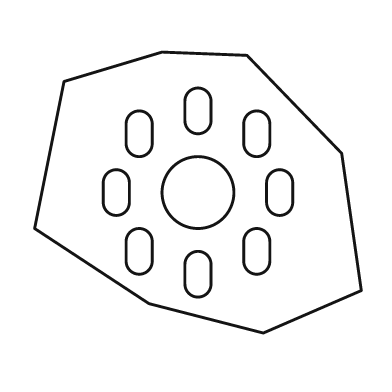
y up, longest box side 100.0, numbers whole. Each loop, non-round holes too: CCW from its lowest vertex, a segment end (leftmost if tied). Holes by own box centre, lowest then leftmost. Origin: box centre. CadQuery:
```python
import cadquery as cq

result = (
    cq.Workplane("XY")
    .moveTo(20.0, -43.0)
    .lineTo(50.0, -30.0)
    .lineTo(44.0, 12.0)
    .lineTo(15.0, 42.0)
    .lineTo(-11.0, 43.0)
    .lineTo(-41.0, 34.0)
    .lineTo(-50.0, -11.0)
    .lineTo(-15.0, -34.0)
    .close()
    .moveTo(-4.0, -28.0)
    .threePointArc((0.0, -32.0), (4.0, -28.0))
    .lineTo(4.0, -22.0)
    .threePointArc((0.0, -18.0), (-4.0, -22.0))
    .close()
    .moveTo(-22.0, -21.0)
    .threePointArc((-18.0, -25.0), (-14.0, -21.0))
    .lineTo(-14.0, -15.0)
    .threePointArc((-18.0, -11.0), (-22.0, -15.0))
    .close()
    .moveTo(14.0, -21.0)
    .threePointArc((18.0, -25.0), (22.0, -21.0))
    .lineTo(22.0, -15.0)
    .threePointArc((18.0, -11.0), (14.0, -15.0))
    .close()
    .moveTo(-29.0, -3.0)
    .threePointArc((-25.0, -7.0), (-21.0, -3.0))
    .lineTo(-21.0, 3.0)
    .threePointArc((-25.0, 7.0), (-29.0, 3.0))
    .close()
    .moveTo(0.0, 0.0)
    .circle(11.0)
    .moveTo(21.0, -3.0)
    .threePointArc((25.0, -7.0), (29.0, -3.0))
    .lineTo(29.0, 3.0)
    .threePointArc((25.0, 7.0), (21.0, 3.0))
    .close()
    .moveTo(-22.0, 15.0)
    .threePointArc((-18.0, 11.0), (-14.0, 15.0))
    .lineTo(-14.0, 21.0)
    .threePointArc((-18.0, 25.0), (-22.0, 21.0))
    .close()
    .moveTo(14.0, 15.0)
    .threePointArc((18.0, 11.0), (22.0, 15.0))
    .lineTo(22.0, 21.0)
    .threePointArc((18.0, 25.0), (14.0, 21.0))
    .close()
    .moveTo(-4.0, 22.0)
    .threePointArc((0.0, 18.0), (4.0, 22.0))
    .lineTo(4.0, 28.0)
    .threePointArc((0.0, 32.0), (-4.0, 28.0))
    .close()
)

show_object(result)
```